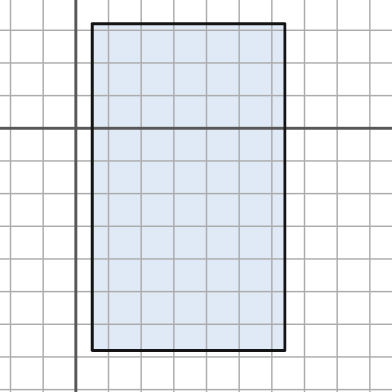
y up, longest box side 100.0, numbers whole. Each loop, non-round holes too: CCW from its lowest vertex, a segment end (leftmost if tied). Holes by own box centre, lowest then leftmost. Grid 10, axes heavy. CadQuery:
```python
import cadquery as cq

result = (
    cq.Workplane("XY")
    .moveTo(5.0, -68.0)
    .lineTo(64.0, -68.0)
    .lineTo(64.0, 32.0)
    .lineTo(5.0, 32.0)
    .close()
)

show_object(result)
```